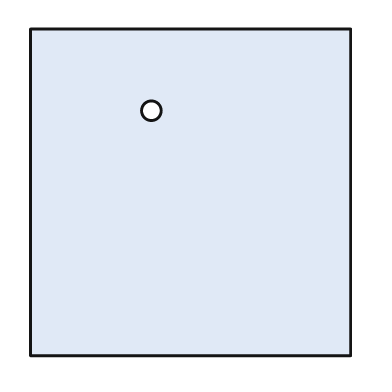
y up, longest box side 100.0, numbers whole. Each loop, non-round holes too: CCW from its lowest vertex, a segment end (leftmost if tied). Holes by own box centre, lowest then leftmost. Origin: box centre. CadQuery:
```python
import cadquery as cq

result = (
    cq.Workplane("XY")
    .moveTo(-49.0, -50.0)
    .lineTo(49.0, -50.0)
    .lineTo(49.0, 50.0)
    .lineTo(-49.0, 50.0)
    .close()
    .moveTo(-12.0, 25.0)
    .circle(3.0)
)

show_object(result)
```